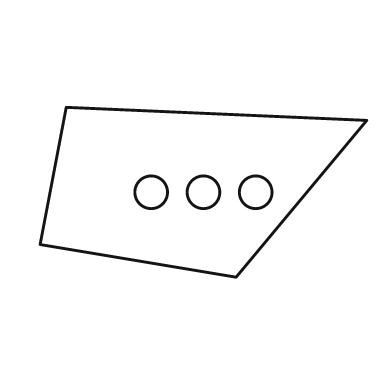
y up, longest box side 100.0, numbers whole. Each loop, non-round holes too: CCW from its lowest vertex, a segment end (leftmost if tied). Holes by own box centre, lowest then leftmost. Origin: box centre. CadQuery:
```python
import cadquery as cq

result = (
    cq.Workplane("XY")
    .moveTo(10.0, -26.0)
    .lineTo(50.0, 22.0)
    .lineTo(-42.0, 26.0)
    .lineTo(-50.0, -16.0)
    .close()
    .moveTo(-16.0, 0.0)
    .circle(5.0)
    .moveTo(0.0, 0.0)
    .circle(5.0)
    .moveTo(16.0, 0.0)
    .circle(5.0)
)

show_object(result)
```